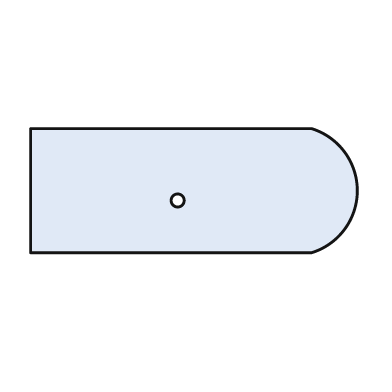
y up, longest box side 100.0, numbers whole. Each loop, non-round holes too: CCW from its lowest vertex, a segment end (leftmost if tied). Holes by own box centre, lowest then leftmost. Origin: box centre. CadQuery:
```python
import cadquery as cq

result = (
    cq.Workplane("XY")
    .moveTo(-50.0, -19.0)
    .lineTo(36.0, -19.0)
    .threePointArc((50.0, 0.0), (36.0, 19.0))
    .lineTo(-50.0, 19.0)
    .close()
    .moveTo(-5.0, -3.0)
    .circle(2.0)
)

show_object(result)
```